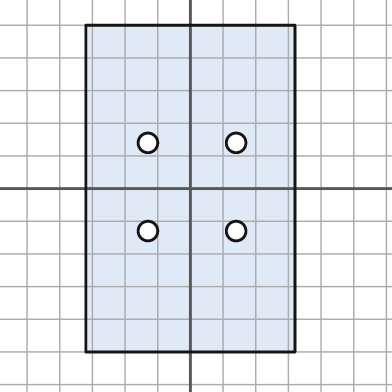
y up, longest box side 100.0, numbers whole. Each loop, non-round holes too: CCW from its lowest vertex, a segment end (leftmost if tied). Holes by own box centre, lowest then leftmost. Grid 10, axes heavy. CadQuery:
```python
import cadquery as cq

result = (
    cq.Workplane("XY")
    .moveTo(-32.0, -50.0)
    .lineTo(32.0, -50.0)
    .lineTo(32.0, 50.0)
    .lineTo(-32.0, 50.0)
    .close()
    .moveTo(-13.0, -13.0)
    .circle(3.0)
    .moveTo(14.0, -13.0)
    .circle(3.0)
    .moveTo(-13.0, 14.0)
    .circle(3.0)
    .moveTo(14.0, 14.0)
    .circle(3.0)
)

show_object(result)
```